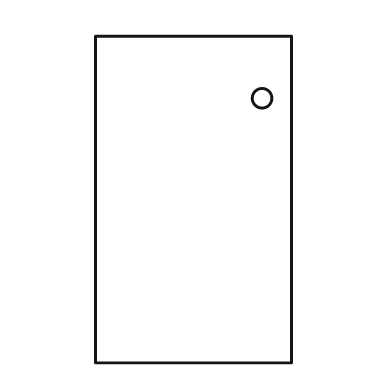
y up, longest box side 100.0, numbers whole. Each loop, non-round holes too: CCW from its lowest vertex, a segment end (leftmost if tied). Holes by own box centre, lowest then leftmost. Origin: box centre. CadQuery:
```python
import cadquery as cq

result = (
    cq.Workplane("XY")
    .moveTo(-30.0, -50.0)
    .lineTo(30.0, -50.0)
    .lineTo(30.0, 50.0)
    .lineTo(-30.0, 50.0)
    .close()
    .moveTo(21.0, 31.0)
    .circle(3.0)
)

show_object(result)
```